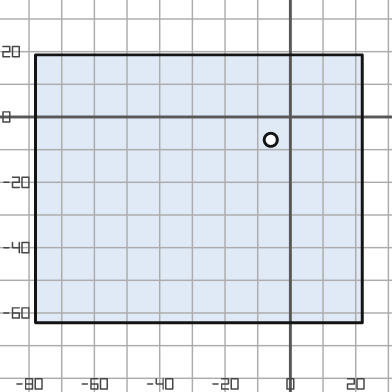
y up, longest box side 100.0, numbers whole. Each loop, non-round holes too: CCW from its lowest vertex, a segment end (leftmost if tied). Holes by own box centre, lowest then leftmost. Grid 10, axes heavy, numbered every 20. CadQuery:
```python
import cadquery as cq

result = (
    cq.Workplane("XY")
    .moveTo(-78.0, -63.0)
    .lineTo(22.0, -63.0)
    .lineTo(22.0, 19.0)
    .lineTo(-78.0, 19.0)
    .close()
    .moveTo(-6.0, -7.0)
    .circle(2.0)
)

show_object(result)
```